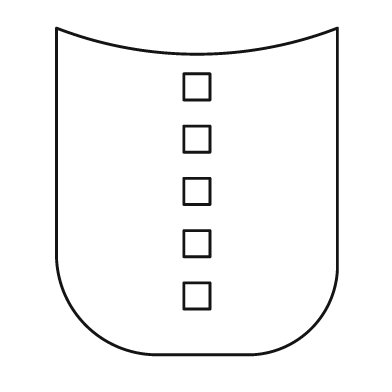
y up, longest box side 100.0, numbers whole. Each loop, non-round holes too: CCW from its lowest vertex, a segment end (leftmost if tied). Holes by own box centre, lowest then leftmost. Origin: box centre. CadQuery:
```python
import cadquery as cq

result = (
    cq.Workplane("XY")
    .moveTo(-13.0, -50.0)
    .lineTo(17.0, -50.0)
    .threePointArc((35.0, -42.0), (43.0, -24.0))
    .lineTo(43.0, 50.0)
    .threePointArc((0.0, 42.0), (-43.0, 50.0))
    .lineTo(-43.0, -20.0)
    .threePointArc((-34.0, -41.0), (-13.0, -50.0))
    .close()
    .moveTo(-4.0, -36.0)
    .lineTo(4.0, -36.0)
    .lineTo(4.0, -28.0)
    .lineTo(-4.0, -28.0)
    .close()
    .moveTo(-4.0, -20.0)
    .lineTo(4.0, -20.0)
    .lineTo(4.0, -12.0)
    .lineTo(-4.0, -12.0)
    .close()
    .moveTo(-4.0, -4.0)
    .lineTo(4.0, -4.0)
    .lineTo(4.0, 4.0)
    .lineTo(-4.0, 4.0)
    .close()
    .moveTo(-4.0, 12.0)
    .lineTo(4.0, 12.0)
    .lineTo(4.0, 20.0)
    .lineTo(-4.0, 20.0)
    .close()
    .moveTo(-4.0, 28.0)
    .lineTo(4.0, 28.0)
    .lineTo(4.0, 36.0)
    .lineTo(-4.0, 36.0)
    .close()
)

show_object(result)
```